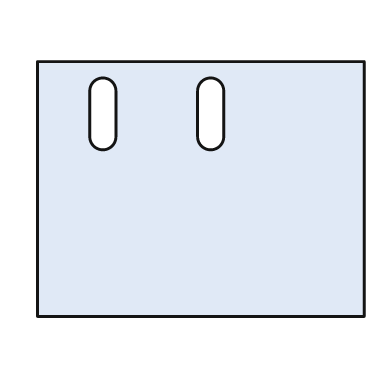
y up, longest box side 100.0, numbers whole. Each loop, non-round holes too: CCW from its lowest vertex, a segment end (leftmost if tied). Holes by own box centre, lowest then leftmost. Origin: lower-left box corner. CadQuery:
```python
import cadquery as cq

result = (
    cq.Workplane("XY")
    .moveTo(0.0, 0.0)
    .lineTo(100.0, 0.0)
    .lineTo(100.0, 78.0)
    .lineTo(0.0, 78.0)
    .close()
    .moveTo(16.0, 55.0)
    .threePointArc((20.0, 51.0), (24.0, 55.0))
    .lineTo(24.0, 69.0)
    .threePointArc((20.0, 73.0), (16.0, 69.0))
    .close()
    .moveTo(49.0, 55.0)
    .threePointArc((53.0, 51.0), (57.0, 55.0))
    .lineTo(57.0, 69.0)
    .threePointArc((53.0, 73.0), (49.0, 69.0))
    .close()
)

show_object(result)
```